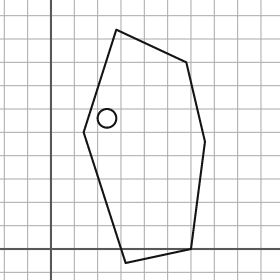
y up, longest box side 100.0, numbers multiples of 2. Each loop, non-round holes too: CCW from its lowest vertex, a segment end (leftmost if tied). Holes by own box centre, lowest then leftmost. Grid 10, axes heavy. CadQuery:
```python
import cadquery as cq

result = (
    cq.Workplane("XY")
    .moveTo(32.0, -6.0)
    .lineTo(60.0, 0.0)
    .lineTo(66.0, 46.0)
    .lineTo(58.0, 80.0)
    .lineTo(28.0, 94.0)
    .lineTo(14.0, 50.0)
    .close()
    .moveTo(24.0, 56.0)
    .circle(4.0)
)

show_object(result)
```